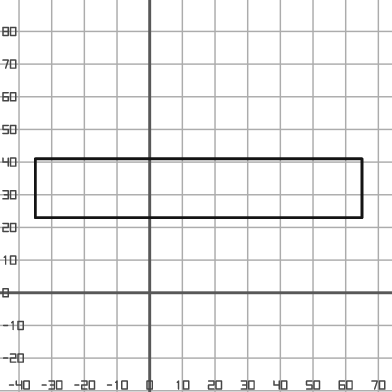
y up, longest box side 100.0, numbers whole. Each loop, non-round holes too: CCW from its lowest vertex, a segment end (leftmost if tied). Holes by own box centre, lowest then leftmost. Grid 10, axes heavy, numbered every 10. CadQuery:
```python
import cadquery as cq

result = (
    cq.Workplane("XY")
    .moveTo(-35.0, 23.0)
    .lineTo(65.0, 23.0)
    .lineTo(65.0, 41.0)
    .lineTo(-35.0, 41.0)
    .close()
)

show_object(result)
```